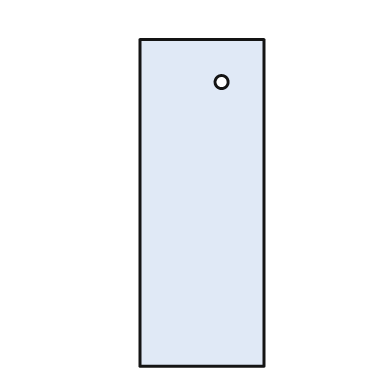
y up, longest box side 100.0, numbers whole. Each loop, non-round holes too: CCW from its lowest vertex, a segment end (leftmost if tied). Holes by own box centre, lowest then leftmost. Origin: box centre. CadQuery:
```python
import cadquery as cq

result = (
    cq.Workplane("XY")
    .moveTo(-19.0, -50.0)
    .lineTo(19.0, -50.0)
    .lineTo(19.0, 50.0)
    .lineTo(-19.0, 50.0)
    .close()
    .moveTo(6.0, 37.0)
    .circle(2.0)
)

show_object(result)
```